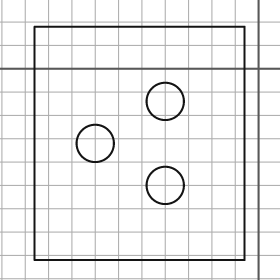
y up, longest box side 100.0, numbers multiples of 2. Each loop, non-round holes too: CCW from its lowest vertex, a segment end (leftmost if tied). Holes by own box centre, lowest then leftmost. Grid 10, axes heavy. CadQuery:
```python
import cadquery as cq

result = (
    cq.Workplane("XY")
    .moveTo(-96.0, -82.0)
    .lineTo(-6.0, -82.0)
    .lineTo(-6.0, 18.0)
    .lineTo(-96.0, 18.0)
    .close()
    .moveTo(-40.0, -50.0)
    .circle(8.0)
    .moveTo(-70.0, -32.0)
    .circle(8.0)
    .moveTo(-40.0, -14.0)
    .circle(8.0)
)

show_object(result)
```